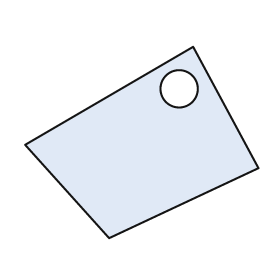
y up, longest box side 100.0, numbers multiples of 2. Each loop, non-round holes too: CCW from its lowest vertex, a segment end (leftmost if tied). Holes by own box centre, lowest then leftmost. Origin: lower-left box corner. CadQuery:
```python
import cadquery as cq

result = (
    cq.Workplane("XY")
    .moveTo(36.0, 0.0)
    .lineTo(100.0, 30.0)
    .lineTo(72.0, 82.0)
    .lineTo(0.0, 40.0)
    .close()
    .moveTo(66.0, 64.0)
    .circle(8.0)
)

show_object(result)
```